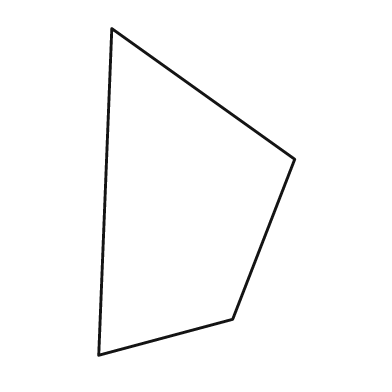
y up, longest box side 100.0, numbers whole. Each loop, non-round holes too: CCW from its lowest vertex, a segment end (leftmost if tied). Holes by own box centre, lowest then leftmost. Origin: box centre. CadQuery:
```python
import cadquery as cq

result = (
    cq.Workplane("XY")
    .moveTo(-30.0, -50.0)
    .lineTo(11.0, -39.0)
    .lineTo(30.0, 10.0)
    .lineTo(-26.0, 50.0)
    .close()
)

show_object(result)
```